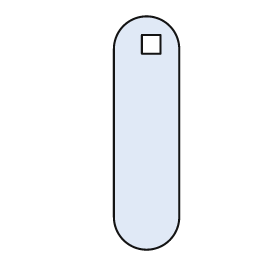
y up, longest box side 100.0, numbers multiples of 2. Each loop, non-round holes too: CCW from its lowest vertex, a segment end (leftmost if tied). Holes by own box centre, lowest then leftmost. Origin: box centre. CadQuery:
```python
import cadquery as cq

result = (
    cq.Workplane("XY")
    .moveTo(-14.0, -36.0)
    .threePointArc((0.0, -50.0), (14.0, -36.0))
    .lineTo(14.0, 36.0)
    .threePointArc((0.0, 50.0), (-14.0, 36.0))
    .close()
    .moveTo(-2.0, 34.0)
    .lineTo(6.0, 34.0)
    .lineTo(6.0, 42.0)
    .lineTo(-2.0, 42.0)
    .close()
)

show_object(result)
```